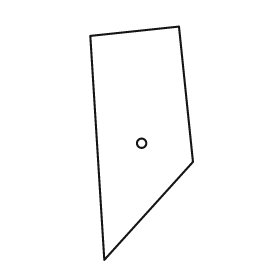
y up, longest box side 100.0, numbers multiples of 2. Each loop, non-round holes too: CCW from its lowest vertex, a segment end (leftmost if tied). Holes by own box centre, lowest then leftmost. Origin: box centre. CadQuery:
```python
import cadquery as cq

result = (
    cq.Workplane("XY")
    .moveTo(-16.0, -50.0)
    .lineTo(22.0, -8.0)
    .lineTo(16.0, 50.0)
    .lineTo(-22.0, 46.0)
    .close()
    .moveTo(0.0, 0.0)
    .circle(2.0)
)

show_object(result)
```